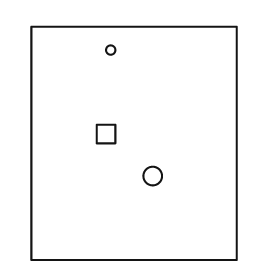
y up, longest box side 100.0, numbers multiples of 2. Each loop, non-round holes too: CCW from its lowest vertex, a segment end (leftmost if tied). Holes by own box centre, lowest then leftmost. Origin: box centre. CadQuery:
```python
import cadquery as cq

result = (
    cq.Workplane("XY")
    .moveTo(-44.0, -50.0)
    .lineTo(44.0, -50.0)
    .lineTo(44.0, 50.0)
    .lineTo(-44.0, 50.0)
    .close()
    .moveTo(8.0, -14.0)
    .circle(4.0)
    .moveTo(-16.0, 0.0)
    .lineTo(-8.0, 0.0)
    .lineTo(-8.0, 8.0)
    .lineTo(-16.0, 8.0)
    .close()
    .moveTo(-10.0, 40.0)
    .circle(2.0)
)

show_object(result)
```